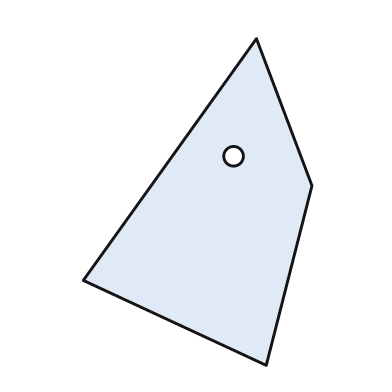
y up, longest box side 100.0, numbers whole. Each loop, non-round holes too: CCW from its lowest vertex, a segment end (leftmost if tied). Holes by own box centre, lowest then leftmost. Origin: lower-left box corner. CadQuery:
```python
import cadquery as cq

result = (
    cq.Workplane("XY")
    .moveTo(56.0, 0.0)
    .lineTo(70.0, 55.0)
    .lineTo(53.0, 100.0)
    .lineTo(0.0, 26.0)
    .close()
    .moveTo(46.0, 64.0)
    .circle(3.0)
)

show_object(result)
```